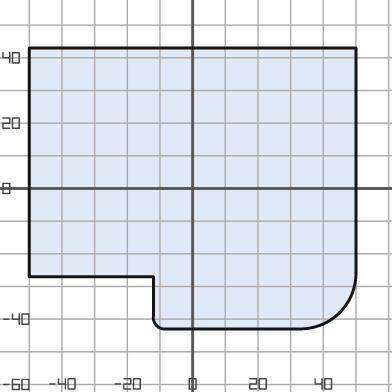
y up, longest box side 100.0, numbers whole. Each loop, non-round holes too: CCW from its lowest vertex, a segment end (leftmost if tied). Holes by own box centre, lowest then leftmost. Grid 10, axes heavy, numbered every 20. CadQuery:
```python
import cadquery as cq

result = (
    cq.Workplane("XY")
    .moveTo(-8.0, -43.0)
    .lineTo(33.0, -43.0)
    .threePointArc((45.0, -38.0), (50.0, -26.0))
    .lineTo(50.0, 43.0)
    .lineTo(-50.0, 43.0)
    .lineTo(-50.0, -27.0)
    .lineTo(-12.0, -27.0)
    .lineTo(-12.0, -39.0)
    .threePointArc((-11.0, -42.0), (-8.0, -43.0))
    .close()
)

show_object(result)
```